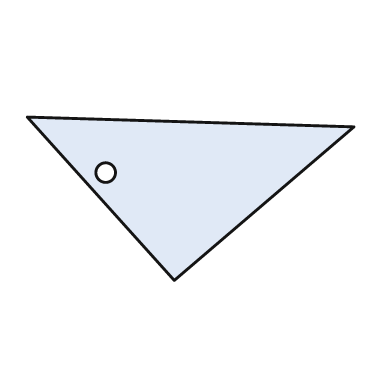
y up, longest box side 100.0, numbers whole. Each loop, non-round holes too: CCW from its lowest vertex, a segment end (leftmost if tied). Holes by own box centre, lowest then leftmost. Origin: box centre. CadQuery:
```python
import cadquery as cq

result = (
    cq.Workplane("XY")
    .moveTo(-5.0, -25.0)
    .lineTo(50.0, 22.0)
    .lineTo(-50.0, 25.0)
    .close()
    .moveTo(-26.0, 8.0)
    .circle(3.0)
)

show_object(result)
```